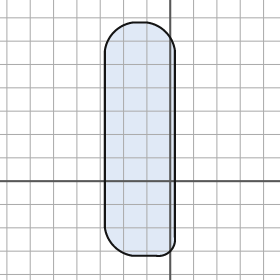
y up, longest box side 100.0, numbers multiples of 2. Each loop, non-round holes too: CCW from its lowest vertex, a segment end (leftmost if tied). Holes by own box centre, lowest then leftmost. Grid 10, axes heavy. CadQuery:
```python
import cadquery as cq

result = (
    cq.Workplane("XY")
    .moveTo(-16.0, -32.0)
    .lineTo(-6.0, -32.0)
    .threePointArc((0.0, -30.0), (2.0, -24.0))
    .lineTo(2.0, 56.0)
    .threePointArc((-2.0, 64.0), (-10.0, 68.0))
    .lineTo(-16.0, 68.0)
    .threePointArc((-24.0, 64.0), (-28.0, 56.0))
    .lineTo(-28.0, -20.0)
    .threePointArc((-24.0, -28.0), (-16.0, -32.0))
    .close()
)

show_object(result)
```